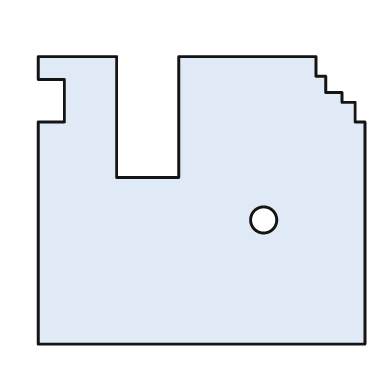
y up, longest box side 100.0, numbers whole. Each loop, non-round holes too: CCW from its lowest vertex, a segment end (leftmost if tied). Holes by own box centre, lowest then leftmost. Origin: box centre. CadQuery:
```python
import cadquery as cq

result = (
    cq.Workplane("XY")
    .moveTo(-50.0, -44.0)
    .lineTo(50.0, -44.0)
    .lineTo(50.0, 24.0)
    .lineTo(47.0, 24.0)
    .lineTo(47.0, 30.0)
    .lineTo(43.0, 30.0)
    .lineTo(43.0, 33.0)
    .lineTo(38.0, 33.0)
    .lineTo(38.0, 38.0)
    .lineTo(35.0, 38.0)
    .lineTo(35.0, 44.0)
    .lineTo(-7.0, 44.0)
    .lineTo(-7.0, 7.0)
    .lineTo(-26.0, 7.0)
    .lineTo(-26.0, 44.0)
    .lineTo(-50.0, 44.0)
    .lineTo(-50.0, 37.0)
    .lineTo(-42.0, 37.0)
    .lineTo(-42.0, 24.0)
    .lineTo(-50.0, 24.0)
    .close()
    .moveTo(19.0, -6.0)
    .circle(4.0)
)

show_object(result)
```